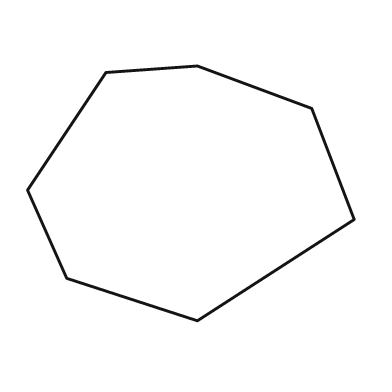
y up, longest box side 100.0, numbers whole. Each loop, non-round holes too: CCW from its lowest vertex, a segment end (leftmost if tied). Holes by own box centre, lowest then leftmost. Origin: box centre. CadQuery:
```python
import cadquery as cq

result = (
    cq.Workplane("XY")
    .moveTo(2.0, -39.0)
    .lineTo(50.0, -8.0)
    .lineTo(37.0, 26.0)
    .lineTo(2.0, 39.0)
    .lineTo(-26.0, 37.0)
    .lineTo(-50.0, 1.0)
    .lineTo(-38.0, -26.0)
    .close()
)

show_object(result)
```